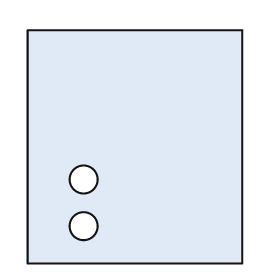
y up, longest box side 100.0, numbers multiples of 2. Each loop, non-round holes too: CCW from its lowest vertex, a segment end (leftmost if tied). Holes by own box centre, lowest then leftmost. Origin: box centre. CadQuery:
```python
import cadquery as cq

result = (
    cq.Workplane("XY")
    .moveTo(-46.0, -50.0)
    .lineTo(46.0, -50.0)
    .lineTo(46.0, 50.0)
    .lineTo(-46.0, 50.0)
    .close()
    .moveTo(-22.0, -34.0)
    .circle(6.0)
    .moveTo(-22.0, -14.0)
    .circle(6.0)
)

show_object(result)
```